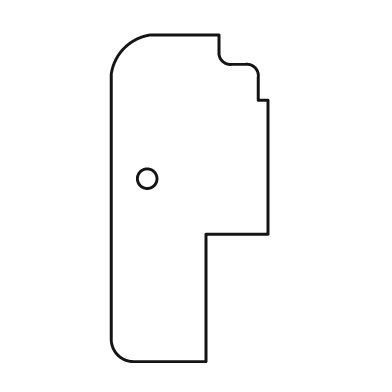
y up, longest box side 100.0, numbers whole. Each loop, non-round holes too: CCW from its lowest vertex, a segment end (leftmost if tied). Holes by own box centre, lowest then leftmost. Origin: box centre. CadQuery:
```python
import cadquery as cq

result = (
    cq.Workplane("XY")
    .moveTo(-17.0, -50.0)
    .lineTo(5.0, -50.0)
    .lineTo(5.0, -11.0)
    .lineTo(24.0, -11.0)
    .lineTo(24.0, 30.0)
    .lineTo(21.0, 30.0)
    .lineTo(21.0, 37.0)
    .threePointArc((20.0, 40.0), (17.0, 41.0))
    .lineTo(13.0, 41.0)
    .threePointArc((10.0, 42.0), (9.0, 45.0))
    .lineTo(9.0, 50.0)
    .lineTo(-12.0, 50.0)
    .threePointArc((-20.0, 46.0), (-24.0, 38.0))
    .lineTo(-24.0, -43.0)
    .threePointArc((-22.0, -48.0), (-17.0, -50.0))
    .close()
    .moveTo(-13.0, 6.0)
    .circle(3.0)
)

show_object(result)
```